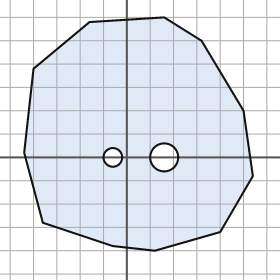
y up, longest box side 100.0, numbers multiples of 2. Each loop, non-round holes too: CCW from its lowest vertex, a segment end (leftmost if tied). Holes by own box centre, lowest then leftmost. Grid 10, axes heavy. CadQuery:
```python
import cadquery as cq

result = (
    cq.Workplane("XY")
    .moveTo(12.0, -40.0)
    .lineTo(40.0, -32.0)
    .lineTo(54.0, -8.0)
    .lineTo(50.0, 20.0)
    .lineTo(32.0, 50.0)
    .lineTo(16.0, 60.0)
    .lineTo(-16.0, 58.0)
    .lineTo(-40.0, 38.0)
    .lineTo(-44.0, 2.0)
    .lineTo(-36.0, -28.0)
    .lineTo(-6.0, -38.0)
    .close()
    .moveTo(-6.0, 0.0)
    .circle(4.0)
    .moveTo(16.0, 0.0)
    .circle(6.0)
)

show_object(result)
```